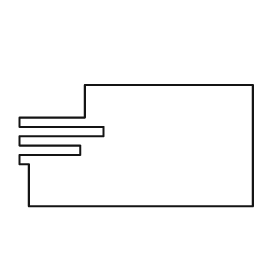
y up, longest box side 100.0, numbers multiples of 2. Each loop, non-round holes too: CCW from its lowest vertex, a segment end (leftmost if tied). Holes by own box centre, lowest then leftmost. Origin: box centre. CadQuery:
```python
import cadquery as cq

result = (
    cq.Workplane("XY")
    .moveTo(-46.0, -26.0)
    .lineTo(50.0, -26.0)
    .lineTo(50.0, 26.0)
    .lineTo(-22.0, 26.0)
    .lineTo(-22.0, 12.0)
    .lineTo(-50.0, 12.0)
    .lineTo(-50.0, 8.0)
    .lineTo(-14.0, 8.0)
    .lineTo(-14.0, 4.0)
    .lineTo(-50.0, 4.0)
    .lineTo(-50.0, 0.0)
    .lineTo(-24.0, 0.0)
    .lineTo(-24.0, -4.0)
    .lineTo(-50.0, -4.0)
    .lineTo(-50.0, -8.0)
    .lineTo(-46.0, -8.0)
    .close()
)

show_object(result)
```